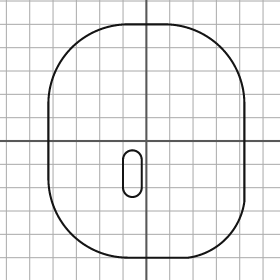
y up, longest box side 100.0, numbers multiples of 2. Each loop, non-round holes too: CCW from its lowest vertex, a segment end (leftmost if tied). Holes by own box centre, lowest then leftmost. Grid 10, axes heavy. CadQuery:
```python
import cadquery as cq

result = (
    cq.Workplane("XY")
    .moveTo(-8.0, -50.0)
    .lineTo(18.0, -50.0)
    .threePointArc((34.0, -42.0), (42.0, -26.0))
    .lineTo(42.0, 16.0)
    .threePointArc((32.0, 40.0), (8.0, 50.0))
    .lineTo(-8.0, 50.0)
    .threePointArc((-32.0, 40.0), (-42.0, 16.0))
    .lineTo(-42.0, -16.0)
    .threePointArc((-32.0, -40.0), (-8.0, -50.0))
    .close()
    .moveTo(-10.0, -20.0)
    .threePointArc((-6.0, -24.0), (-2.0, -20.0))
    .lineTo(-2.0, -8.0)
    .threePointArc((-6.0, -4.0), (-10.0, -8.0))
    .close()
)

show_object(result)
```